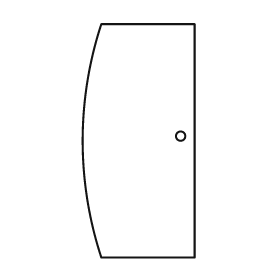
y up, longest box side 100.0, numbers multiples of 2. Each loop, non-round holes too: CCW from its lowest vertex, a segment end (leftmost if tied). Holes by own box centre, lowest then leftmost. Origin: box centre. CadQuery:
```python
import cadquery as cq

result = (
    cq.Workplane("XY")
    .moveTo(-16.0, -50.0)
    .lineTo(24.0, -50.0)
    .lineTo(24.0, 50.0)
    .lineTo(-16.0, 50.0)
    .threePointArc((-24.0, 0.0), (-16.0, -50.0))
    .close()
    .moveTo(18.0, 2.0)
    .circle(2.0)
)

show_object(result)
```